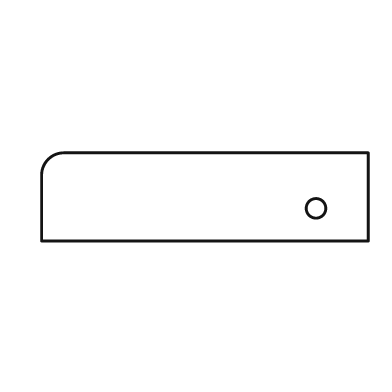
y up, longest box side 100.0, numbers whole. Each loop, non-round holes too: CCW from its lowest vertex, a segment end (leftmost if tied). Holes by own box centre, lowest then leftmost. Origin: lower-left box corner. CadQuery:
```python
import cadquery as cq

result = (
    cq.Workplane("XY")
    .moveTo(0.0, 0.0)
    .lineTo(100.0, 0.0)
    .lineTo(100.0, 27.0)
    .lineTo(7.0, 27.0)
    .threePointArc((2.0, 25.0), (0.0, 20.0))
    .close()
    .moveTo(84.0, 10.0)
    .circle(3.0)
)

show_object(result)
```